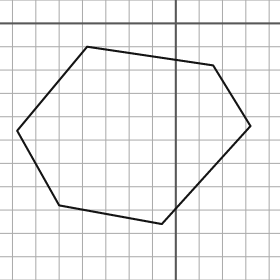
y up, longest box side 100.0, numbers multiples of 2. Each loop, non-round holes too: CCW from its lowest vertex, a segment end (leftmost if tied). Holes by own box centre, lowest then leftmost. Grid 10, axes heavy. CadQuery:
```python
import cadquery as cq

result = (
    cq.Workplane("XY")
    .moveTo(-6.0, -86.0)
    .lineTo(32.0, -44.0)
    .lineTo(16.0, -18.0)
    .lineTo(-38.0, -10.0)
    .lineTo(-68.0, -46.0)
    .lineTo(-50.0, -78.0)
    .close()
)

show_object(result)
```